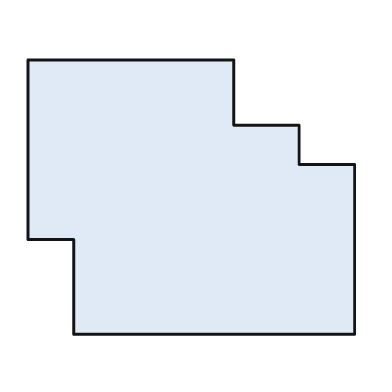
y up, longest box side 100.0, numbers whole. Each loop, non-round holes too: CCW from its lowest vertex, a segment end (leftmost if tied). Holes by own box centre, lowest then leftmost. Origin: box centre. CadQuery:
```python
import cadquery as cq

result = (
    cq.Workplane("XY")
    .moveTo(-36.0, -42.0)
    .lineTo(50.0, -42.0)
    .lineTo(50.0, 10.0)
    .lineTo(33.0, 10.0)
    .lineTo(33.0, 22.0)
    .lineTo(13.0, 22.0)
    .lineTo(13.0, 42.0)
    .lineTo(-50.0, 42.0)
    .lineTo(-50.0, -13.0)
    .lineTo(-36.0, -13.0)
    .close()
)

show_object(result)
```